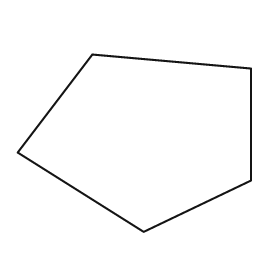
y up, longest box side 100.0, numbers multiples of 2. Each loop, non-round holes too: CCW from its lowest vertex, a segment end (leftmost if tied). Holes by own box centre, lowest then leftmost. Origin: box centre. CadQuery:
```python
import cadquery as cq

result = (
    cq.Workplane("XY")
    .moveTo(4.0, -38.0)
    .lineTo(50.0, -16.0)
    .lineTo(50.0, 32.0)
    .lineTo(-18.0, 38.0)
    .lineTo(-50.0, -4.0)
    .close()
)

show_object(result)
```